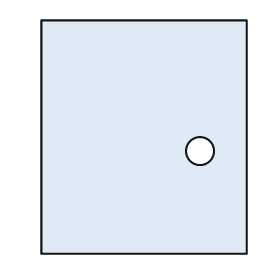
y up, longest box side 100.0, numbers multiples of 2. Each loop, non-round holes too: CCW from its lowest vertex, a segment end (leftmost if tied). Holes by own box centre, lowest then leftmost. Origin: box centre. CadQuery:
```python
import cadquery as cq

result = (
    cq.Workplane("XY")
    .moveTo(-44.0, -50.0)
    .lineTo(44.0, -50.0)
    .lineTo(44.0, 50.0)
    .lineTo(-44.0, 50.0)
    .close()
    .moveTo(24.0, -6.0)
    .circle(6.0)
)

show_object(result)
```